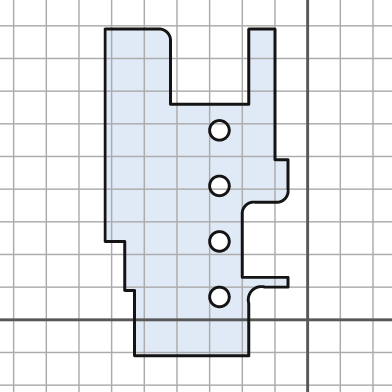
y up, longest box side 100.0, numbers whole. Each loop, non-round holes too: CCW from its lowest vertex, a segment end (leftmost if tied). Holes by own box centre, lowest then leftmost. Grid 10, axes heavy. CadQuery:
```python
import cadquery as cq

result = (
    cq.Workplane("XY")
    .moveTo(-53.0, -11.0)
    .lineTo(-18.0, -11.0)
    .lineTo(-18.0, 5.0)
    .threePointArc((-17.0, 9.0), (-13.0, 10.0))
    .lineTo(-6.0, 10.0)
    .lineTo(-6.0, 13.0)
    .lineTo(-20.0, 13.0)
    .lineTo(-20.0, 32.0)
    .threePointArc((-19.0, 35.0), (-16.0, 36.0))
    .lineTo(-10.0, 36.0)
    .threePointArc((-7.0, 37.0), (-6.0, 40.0))
    .lineTo(-6.0, 49.0)
    .lineTo(-10.0, 49.0)
    .lineTo(-10.0, 89.0)
    .lineTo(-18.0, 89.0)
    .lineTo(-18.0, 66.0)
    .lineTo(-42.0, 66.0)
    .lineTo(-42.0, 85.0)
    .threePointArc((-43.0, 88.0), (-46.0, 89.0))
    .lineTo(-62.0, 89.0)
    .lineTo(-62.0, 24.0)
    .lineTo(-56.0, 24.0)
    .lineTo(-56.0, 9.0)
    .lineTo(-53.0, 9.0)
    .close()
    .moveTo(-27.0, 7.0)
    .circle(3.0)
    .moveTo(-27.0, 24.0)
    .circle(3.0)
    .moveTo(-27.0, 41.0)
    .circle(3.0)
    .moveTo(-27.0, 58.0)
    .circle(3.0)
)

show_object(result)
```